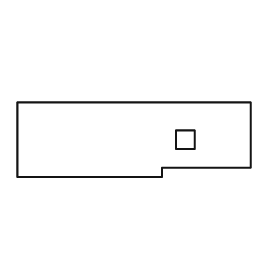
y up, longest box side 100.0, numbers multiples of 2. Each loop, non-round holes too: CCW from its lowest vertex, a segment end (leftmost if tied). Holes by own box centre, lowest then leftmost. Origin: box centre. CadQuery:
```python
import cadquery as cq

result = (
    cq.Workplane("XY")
    .moveTo(-50.0, -16.0)
    .lineTo(12.0, -16.0)
    .lineTo(12.0, -12.0)
    .lineTo(50.0, -12.0)
    .lineTo(50.0, 16.0)
    .lineTo(-50.0, 16.0)
    .close()
    .moveTo(18.0, -4.0)
    .lineTo(26.0, -4.0)
    .lineTo(26.0, 4.0)
    .lineTo(18.0, 4.0)
    .close()
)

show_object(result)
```